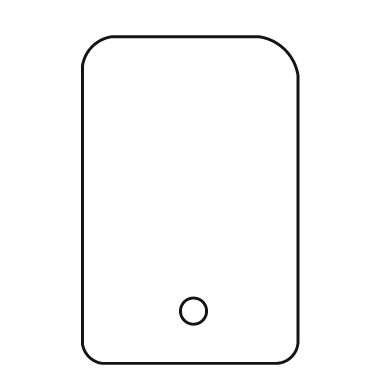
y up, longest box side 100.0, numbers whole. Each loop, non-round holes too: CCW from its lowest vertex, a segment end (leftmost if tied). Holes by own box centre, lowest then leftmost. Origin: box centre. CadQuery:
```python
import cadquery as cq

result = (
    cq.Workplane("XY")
    .moveTo(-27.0, -50.0)
    .lineTo(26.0, -50.0)
    .threePointArc((31.0, -48.0), (33.0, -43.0))
    .lineTo(33.0, 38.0)
    .threePointArc((29.0, 46.0), (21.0, 50.0))
    .lineTo(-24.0, 50.0)
    .threePointArc((-30.0, 47.0), (-33.0, 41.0))
    .lineTo(-33.0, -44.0)
    .threePointArc((-31.0, -48.0), (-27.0, -50.0))
    .close()
    .moveTo(1.0, -34.0)
    .circle(4.0)
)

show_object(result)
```